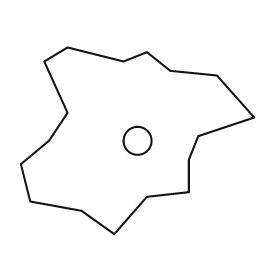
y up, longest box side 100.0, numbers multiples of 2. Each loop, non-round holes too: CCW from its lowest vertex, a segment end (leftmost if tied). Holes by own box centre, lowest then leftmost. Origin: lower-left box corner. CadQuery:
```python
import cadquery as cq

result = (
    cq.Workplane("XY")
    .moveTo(40.0, 0.0)
    .lineTo(54.0, 16.0)
    .lineTo(72.0, 18.0)
    .lineTo(72.0, 32.0)
    .lineTo(76.0, 42.0)
    .lineTo(100.0, 50.0)
    .lineTo(84.0, 68.0)
    .lineTo(64.0, 70.0)
    .lineTo(54.0, 78.0)
    .lineTo(44.0, 74.0)
    .lineTo(20.0, 80.0)
    .lineTo(10.0, 74.0)
    .lineTo(20.0, 52.0)
    .lineTo(12.0, 40.0)
    .lineTo(0.0, 30.0)
    .lineTo(4.0, 14.0)
    .lineTo(26.0, 10.0)
    .close()
    .moveTo(50.0, 40.0)
    .circle(6.0)
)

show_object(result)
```